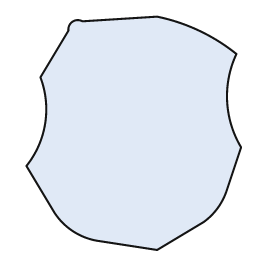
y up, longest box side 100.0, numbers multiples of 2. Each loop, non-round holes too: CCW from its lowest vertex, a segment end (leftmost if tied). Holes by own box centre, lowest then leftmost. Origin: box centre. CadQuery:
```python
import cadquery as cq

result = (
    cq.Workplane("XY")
    .moveTo(10.0, -50.0)
    .lineTo(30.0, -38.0)
    .threePointArc((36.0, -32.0), (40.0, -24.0))
    .lineTo(46.0, -6.0)
    .threePointArc((40.0, 14.0), (44.0, 34.0))
    .threePointArc((28.0, 44.0), (10.0, 50.0))
    .lineTo(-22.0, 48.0)
    .threePointArc((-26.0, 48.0), (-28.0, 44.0))
    .lineTo(-40.0, 24.0)
    .threePointArc((-38.0, 4.0), (-46.0, -14.0))
    .lineTo(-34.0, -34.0)
    .threePointArc((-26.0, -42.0), (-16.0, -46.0))
    .close()
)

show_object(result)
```